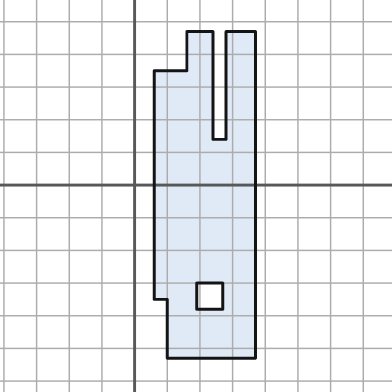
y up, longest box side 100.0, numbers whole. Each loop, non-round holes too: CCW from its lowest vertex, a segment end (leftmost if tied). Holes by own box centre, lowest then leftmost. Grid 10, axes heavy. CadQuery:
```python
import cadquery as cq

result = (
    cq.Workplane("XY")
    .moveTo(10.0, -53.0)
    .lineTo(37.0, -53.0)
    .lineTo(37.0, 47.0)
    .lineTo(28.0, 47.0)
    .lineTo(28.0, 14.0)
    .lineTo(24.0, 14.0)
    .lineTo(24.0, 47.0)
    .lineTo(16.0, 47.0)
    .lineTo(16.0, 35.0)
    .lineTo(6.0, 35.0)
    .lineTo(6.0, -35.0)
    .lineTo(10.0, -35.0)
    .close()
    .moveTo(19.0, -38.0)
    .lineTo(27.0, -38.0)
    .lineTo(27.0, -30.0)
    .lineTo(19.0, -30.0)
    .close()
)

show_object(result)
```